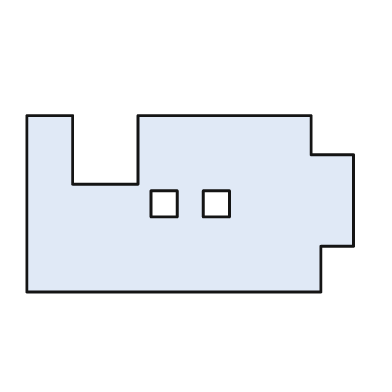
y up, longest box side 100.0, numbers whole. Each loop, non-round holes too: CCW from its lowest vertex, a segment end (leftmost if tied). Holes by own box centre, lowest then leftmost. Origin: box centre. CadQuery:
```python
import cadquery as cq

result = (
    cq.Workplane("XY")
    .moveTo(-50.0, -27.0)
    .lineTo(40.0, -27.0)
    .lineTo(40.0, -13.0)
    .lineTo(50.0, -13.0)
    .lineTo(50.0, 15.0)
    .lineTo(37.0, 15.0)
    .lineTo(37.0, 27.0)
    .lineTo(-16.0, 27.0)
    .lineTo(-16.0, 6.0)
    .lineTo(-36.0, 6.0)
    .lineTo(-36.0, 27.0)
    .lineTo(-50.0, 27.0)
    .close()
    .moveTo(-12.0, -4.0)
    .lineTo(-4.0, -4.0)
    .lineTo(-4.0, 4.0)
    .lineTo(-12.0, 4.0)
    .close()
    .moveTo(4.0, -4.0)
    .lineTo(12.0, -4.0)
    .lineTo(12.0, 4.0)
    .lineTo(4.0, 4.0)
    .close()
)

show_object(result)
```